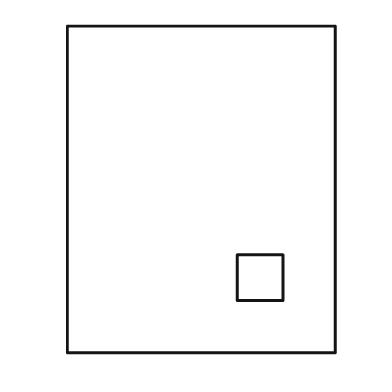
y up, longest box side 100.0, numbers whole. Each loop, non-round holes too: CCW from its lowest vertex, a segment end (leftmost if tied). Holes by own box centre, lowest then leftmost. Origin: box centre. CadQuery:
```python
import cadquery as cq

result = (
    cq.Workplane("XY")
    .moveTo(-41.0, -50.0)
    .lineTo(41.0, -50.0)
    .lineTo(41.0, 50.0)
    .lineTo(-41.0, 50.0)
    .close()
    .moveTo(11.0, -34.0)
    .lineTo(25.0, -34.0)
    .lineTo(25.0, -20.0)
    .lineTo(11.0, -20.0)
    .close()
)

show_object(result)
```